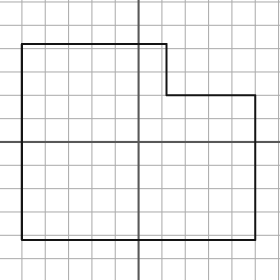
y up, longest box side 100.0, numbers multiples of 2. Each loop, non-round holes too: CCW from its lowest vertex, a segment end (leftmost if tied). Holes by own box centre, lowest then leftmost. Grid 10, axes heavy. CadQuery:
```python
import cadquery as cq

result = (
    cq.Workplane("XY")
    .moveTo(-50.0, -42.0)
    .lineTo(50.0, -42.0)
    .lineTo(50.0, 20.0)
    .lineTo(12.0, 20.0)
    .lineTo(12.0, 42.0)
    .lineTo(-50.0, 42.0)
    .close()
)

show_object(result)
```